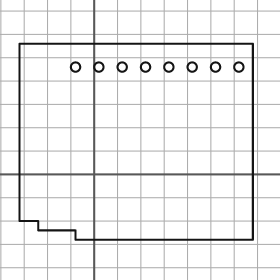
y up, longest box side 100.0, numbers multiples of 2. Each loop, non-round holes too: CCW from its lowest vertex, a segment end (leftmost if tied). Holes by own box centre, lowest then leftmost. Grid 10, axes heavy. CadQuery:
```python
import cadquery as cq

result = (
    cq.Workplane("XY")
    .moveTo(-8.0, -28.0)
    .lineTo(68.0, -28.0)
    .lineTo(68.0, 56.0)
    .lineTo(-32.0, 56.0)
    .lineTo(-32.0, -20.0)
    .lineTo(-24.0, -20.0)
    .lineTo(-24.0, -24.0)
    .lineTo(-8.0, -24.0)
    .close()
    .moveTo(-8.0, 46.0)
    .circle(2.0)
    .moveTo(2.0, 46.0)
    .circle(2.0)
    .moveTo(12.0, 46.0)
    .circle(2.0)
    .moveTo(22.0, 46.0)
    .circle(2.0)
    .moveTo(32.0, 46.0)
    .circle(2.0)
    .moveTo(42.0, 46.0)
    .circle(2.0)
    .moveTo(52.0, 46.0)
    .circle(2.0)
    .moveTo(62.0, 46.0)
    .circle(2.0)
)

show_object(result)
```